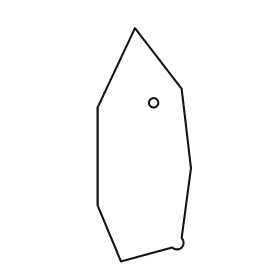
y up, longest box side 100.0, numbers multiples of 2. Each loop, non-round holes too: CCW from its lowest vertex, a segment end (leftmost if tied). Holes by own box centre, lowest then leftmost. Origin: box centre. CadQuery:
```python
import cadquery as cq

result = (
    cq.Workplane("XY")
    .moveTo(-10.0, -50.0)
    .lineTo(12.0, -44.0)
    .threePointArc((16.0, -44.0), (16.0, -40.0))
    .lineTo(20.0, -10.0)
    .lineTo(16.0, 24.0)
    .lineTo(-4.0, 50.0)
    .lineTo(-20.0, 16.0)
    .lineTo(-20.0, -26.0)
    .close()
    .moveTo(4.0, 18.0)
    .circle(2.0)
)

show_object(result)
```